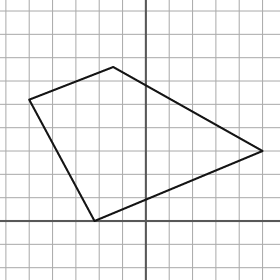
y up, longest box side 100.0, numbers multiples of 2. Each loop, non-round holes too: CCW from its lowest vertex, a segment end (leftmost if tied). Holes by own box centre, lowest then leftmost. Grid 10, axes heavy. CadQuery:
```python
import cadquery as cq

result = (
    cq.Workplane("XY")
    .moveTo(-22.0, 0.0)
    .lineTo(50.0, 30.0)
    .lineTo(-14.0, 66.0)
    .lineTo(-50.0, 52.0)
    .close()
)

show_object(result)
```